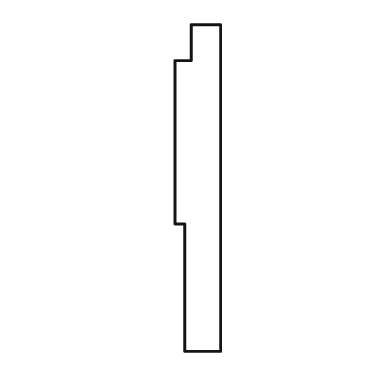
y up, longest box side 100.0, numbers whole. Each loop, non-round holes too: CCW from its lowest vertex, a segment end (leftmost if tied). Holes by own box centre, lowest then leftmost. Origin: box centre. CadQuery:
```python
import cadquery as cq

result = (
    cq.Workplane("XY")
    .moveTo(-4.0, -50.0)
    .lineTo(7.0, -50.0)
    .lineTo(7.0, 50.0)
    .lineTo(-2.0, 50.0)
    .lineTo(-2.0, 39.0)
    .lineTo(-7.0, 39.0)
    .lineTo(-7.0, -11.0)
    .lineTo(-4.0, -11.0)
    .close()
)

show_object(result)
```